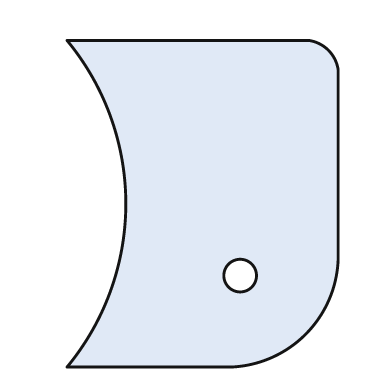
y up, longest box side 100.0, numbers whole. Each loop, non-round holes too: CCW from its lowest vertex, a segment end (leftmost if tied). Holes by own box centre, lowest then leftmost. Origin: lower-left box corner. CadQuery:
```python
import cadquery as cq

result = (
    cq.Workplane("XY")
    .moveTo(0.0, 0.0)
    .lineTo(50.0, 0.0)
    .threePointArc((73.0, 10.0), (83.0, 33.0))
    .lineTo(83.0, 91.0)
    .threePointArc((80.0, 97.0), (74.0, 100.0))
    .lineTo(0.0, 100.0)
    .threePointArc((18.0, 50.0), (0.0, 0.0))
    .close()
    .moveTo(53.0, 28.0)
    .circle(5.0)
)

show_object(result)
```